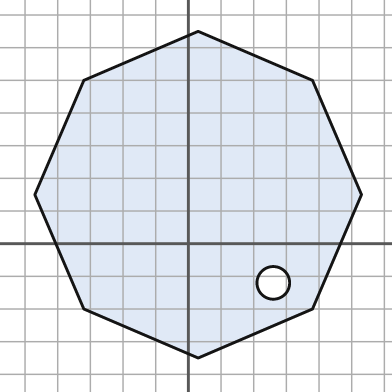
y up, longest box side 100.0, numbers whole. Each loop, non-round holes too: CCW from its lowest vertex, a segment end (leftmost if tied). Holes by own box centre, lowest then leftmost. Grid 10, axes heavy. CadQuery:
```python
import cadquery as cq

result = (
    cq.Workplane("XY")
    .moveTo(3.0, -35.0)
    .lineTo(38.0, -20.0)
    .lineTo(53.0, 15.0)
    .lineTo(38.0, 50.0)
    .lineTo(3.0, 65.0)
    .lineTo(-32.0, 50.0)
    .lineTo(-47.0, 15.0)
    .lineTo(-32.0, -20.0)
    .close()
    .moveTo(26.0, -12.0)
    .circle(5.0)
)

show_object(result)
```